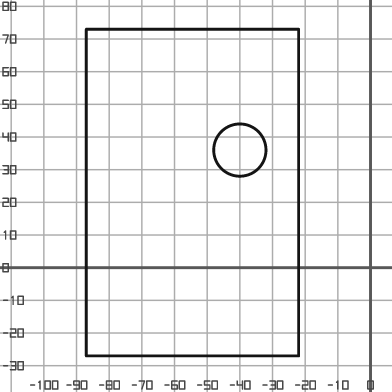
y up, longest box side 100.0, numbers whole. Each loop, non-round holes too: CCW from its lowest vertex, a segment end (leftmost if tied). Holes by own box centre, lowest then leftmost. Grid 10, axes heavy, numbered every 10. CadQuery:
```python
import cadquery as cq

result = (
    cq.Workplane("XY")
    .moveTo(-87.0, -27.0)
    .lineTo(-22.0, -27.0)
    .lineTo(-22.0, 73.0)
    .lineTo(-87.0, 73.0)
    .close()
    .moveTo(-40.0, 36.0)
    .circle(8.0)
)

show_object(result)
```